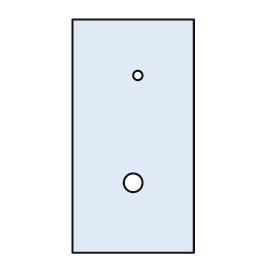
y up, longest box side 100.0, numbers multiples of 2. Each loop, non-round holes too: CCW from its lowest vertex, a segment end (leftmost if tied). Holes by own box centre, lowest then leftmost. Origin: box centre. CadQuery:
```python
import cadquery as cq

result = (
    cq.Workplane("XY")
    .moveTo(-26.0, -50.0)
    .lineTo(26.0, -50.0)
    .lineTo(26.0, 50.0)
    .lineTo(-26.0, 50.0)
    .close()
    .moveTo(0.0, -20.0)
    .circle(4.0)
    .moveTo(2.0, 26.0)
    .circle(2.0)
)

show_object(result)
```